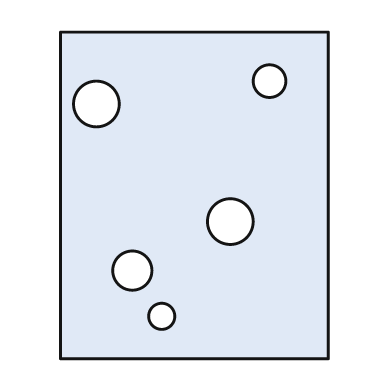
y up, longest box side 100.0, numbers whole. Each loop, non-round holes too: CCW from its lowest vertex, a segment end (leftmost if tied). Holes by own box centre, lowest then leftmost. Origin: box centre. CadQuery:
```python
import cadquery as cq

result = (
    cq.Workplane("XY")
    .moveTo(-41.0, -50.0)
    .lineTo(41.0, -50.0)
    .lineTo(41.0, 50.0)
    .lineTo(-41.0, 50.0)
    .close()
    .moveTo(-10.0, -37.0)
    .circle(4.0)
    .moveTo(-19.0, -23.0)
    .circle(6.0)
    .moveTo(11.0, -8.0)
    .circle(7.0)
    .moveTo(-30.0, 28.0)
    .circle(7.0)
    .moveTo(23.0, 35.0)
    .circle(5.0)
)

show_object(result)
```